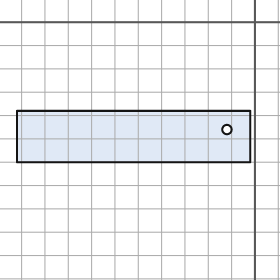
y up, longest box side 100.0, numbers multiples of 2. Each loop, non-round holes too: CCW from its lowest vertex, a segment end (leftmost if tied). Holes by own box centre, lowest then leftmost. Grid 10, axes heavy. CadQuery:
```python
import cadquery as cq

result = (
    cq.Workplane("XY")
    .moveTo(-102.0, -60.0)
    .lineTo(-2.0, -60.0)
    .lineTo(-2.0, -38.0)
    .lineTo(-102.0, -38.0)
    .close()
    .moveTo(-12.0, -46.0)
    .circle(2.0)
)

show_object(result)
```